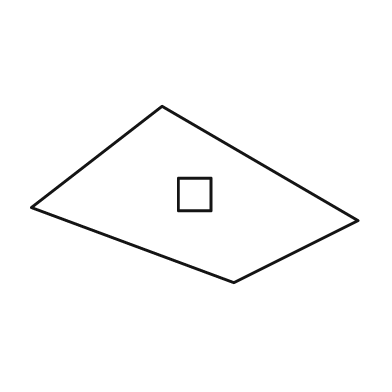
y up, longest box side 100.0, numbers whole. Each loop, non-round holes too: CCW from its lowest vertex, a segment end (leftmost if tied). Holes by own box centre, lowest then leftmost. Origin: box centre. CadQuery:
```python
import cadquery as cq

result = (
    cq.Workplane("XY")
    .moveTo(12.0, -27.0)
    .lineTo(50.0, -8.0)
    .lineTo(-10.0, 27.0)
    .lineTo(-50.0, -4.0)
    .close()
    .moveTo(-5.0, -5.0)
    .lineTo(5.0, -5.0)
    .lineTo(5.0, 5.0)
    .lineTo(-5.0, 5.0)
    .close()
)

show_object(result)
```